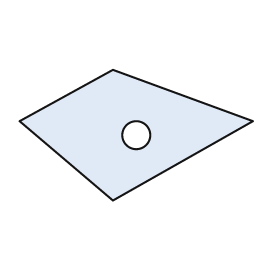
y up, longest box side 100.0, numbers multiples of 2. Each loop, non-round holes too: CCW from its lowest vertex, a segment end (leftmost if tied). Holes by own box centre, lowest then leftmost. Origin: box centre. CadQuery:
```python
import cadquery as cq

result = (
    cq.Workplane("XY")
    .moveTo(-10.0, -28.0)
    .lineTo(50.0, 6.0)
    .lineTo(-10.0, 28.0)
    .lineTo(-50.0, 6.0)
    .close()
    .moveTo(0.0, 0.0)
    .circle(6.0)
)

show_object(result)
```